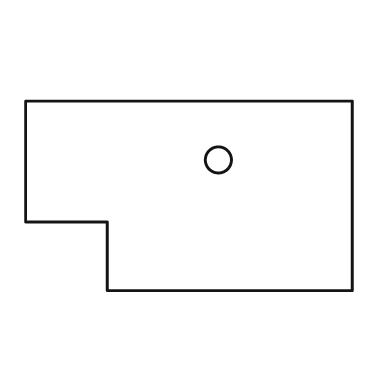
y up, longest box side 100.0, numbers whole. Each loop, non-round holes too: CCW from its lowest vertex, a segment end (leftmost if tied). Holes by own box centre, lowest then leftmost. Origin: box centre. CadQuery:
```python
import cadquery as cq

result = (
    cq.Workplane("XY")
    .moveTo(-25.0, -29.0)
    .lineTo(50.0, -29.0)
    .lineTo(50.0, 29.0)
    .lineTo(-50.0, 29.0)
    .lineTo(-50.0, -8.0)
    .lineTo(-25.0, -8.0)
    .close()
    .moveTo(9.0, 11.0)
    .circle(4.0)
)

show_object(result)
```